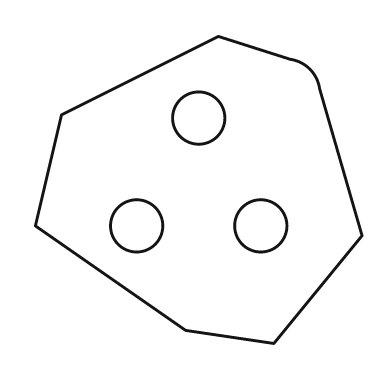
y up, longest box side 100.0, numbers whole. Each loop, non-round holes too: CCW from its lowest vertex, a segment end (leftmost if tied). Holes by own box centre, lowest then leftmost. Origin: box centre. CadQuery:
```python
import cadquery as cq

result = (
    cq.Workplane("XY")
    .moveTo(23.0, -47.0)
    .lineTo(50.0, -14.0)
    .lineTo(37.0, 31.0)
    .threePointArc((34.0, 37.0), (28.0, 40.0))
    .lineTo(6.0, 47.0)
    .lineTo(-42.0, 23.0)
    .lineTo(-50.0, -11.0)
    .lineTo(-4.0, -43.0)
    .close()
    .moveTo(-19.0, -11.0)
    .circle(8.0)
    .moveTo(19.0, -11.0)
    .circle(8.0)
    .moveTo(0.0, 22.0)
    .circle(8.0)
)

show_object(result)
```